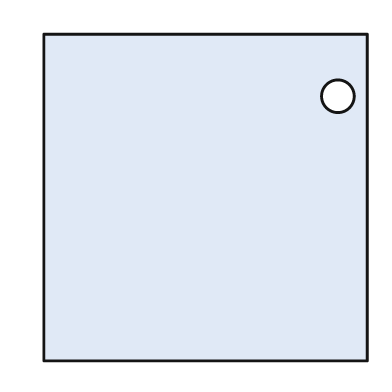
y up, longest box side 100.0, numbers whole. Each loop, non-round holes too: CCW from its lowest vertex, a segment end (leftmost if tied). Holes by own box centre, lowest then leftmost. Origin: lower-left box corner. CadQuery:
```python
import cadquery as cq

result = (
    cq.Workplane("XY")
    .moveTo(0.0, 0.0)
    .lineTo(99.0, 0.0)
    .lineTo(99.0, 100.0)
    .lineTo(0.0, 100.0)
    .close()
    .moveTo(90.0, 81.0)
    .circle(5.0)
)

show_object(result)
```